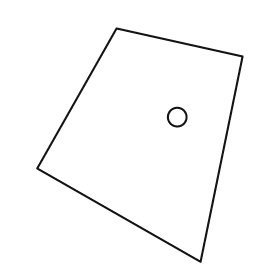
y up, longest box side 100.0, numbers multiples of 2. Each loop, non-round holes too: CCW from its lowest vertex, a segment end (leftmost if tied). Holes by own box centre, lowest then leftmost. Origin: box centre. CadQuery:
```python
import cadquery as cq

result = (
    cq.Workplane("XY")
    .moveTo(26.0, -50.0)
    .lineTo(44.0, 38.0)
    .lineTo(-10.0, 50.0)
    .lineTo(-44.0, -10.0)
    .close()
    .moveTo(16.0, 12.0)
    .circle(4.0)
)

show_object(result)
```